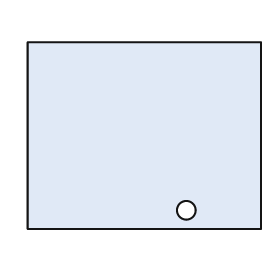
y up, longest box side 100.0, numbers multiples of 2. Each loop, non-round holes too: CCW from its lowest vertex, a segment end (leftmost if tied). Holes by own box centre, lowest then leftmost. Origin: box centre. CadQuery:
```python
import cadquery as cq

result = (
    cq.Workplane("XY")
    .moveTo(-50.0, -40.0)
    .lineTo(50.0, -40.0)
    .lineTo(50.0, 40.0)
    .lineTo(-50.0, 40.0)
    .close()
    .moveTo(18.0, -32.0)
    .circle(4.0)
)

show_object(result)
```